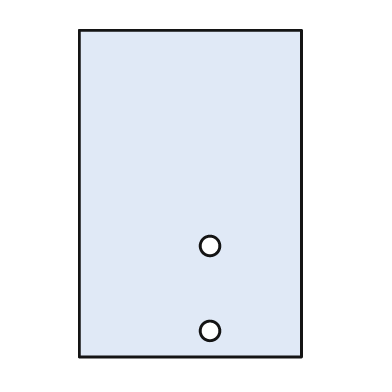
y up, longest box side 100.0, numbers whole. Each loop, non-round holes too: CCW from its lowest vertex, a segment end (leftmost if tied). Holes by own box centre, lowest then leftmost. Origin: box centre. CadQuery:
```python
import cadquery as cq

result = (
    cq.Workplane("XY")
    .moveTo(-34.0, -50.0)
    .lineTo(34.0, -50.0)
    .lineTo(34.0, 50.0)
    .lineTo(-34.0, 50.0)
    .close()
    .moveTo(6.0, -42.0)
    .circle(3.0)
    .moveTo(6.0, -16.0)
    .circle(3.0)
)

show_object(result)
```